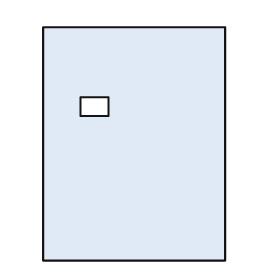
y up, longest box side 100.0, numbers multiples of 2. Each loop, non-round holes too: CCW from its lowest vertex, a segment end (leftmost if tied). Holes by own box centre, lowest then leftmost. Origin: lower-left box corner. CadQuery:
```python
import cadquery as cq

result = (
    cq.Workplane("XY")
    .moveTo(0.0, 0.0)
    .lineTo(78.0, 0.0)
    .lineTo(78.0, 100.0)
    .lineTo(0.0, 100.0)
    .close()
    .moveTo(16.0, 62.0)
    .lineTo(28.0, 62.0)
    .lineTo(28.0, 70.0)
    .lineTo(16.0, 70.0)
    .close()
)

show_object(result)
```